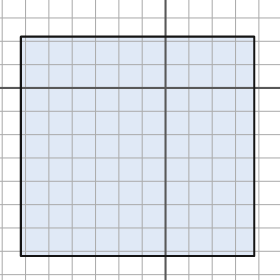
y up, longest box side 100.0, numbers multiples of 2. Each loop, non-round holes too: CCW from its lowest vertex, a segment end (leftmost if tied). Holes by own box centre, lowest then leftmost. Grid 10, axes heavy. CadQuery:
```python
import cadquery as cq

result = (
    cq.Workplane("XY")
    .moveTo(-62.0, -72.0)
    .lineTo(38.0, -72.0)
    .lineTo(38.0, 22.0)
    .lineTo(-62.0, 22.0)
    .close()
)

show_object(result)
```